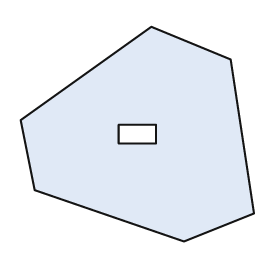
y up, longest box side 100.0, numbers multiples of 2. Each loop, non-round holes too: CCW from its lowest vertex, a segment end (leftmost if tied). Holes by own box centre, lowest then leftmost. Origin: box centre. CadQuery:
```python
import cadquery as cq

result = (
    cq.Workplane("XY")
    .moveTo(20.0, -46.0)
    .lineTo(50.0, -34.0)
    .lineTo(40.0, 32.0)
    .lineTo(6.0, 46.0)
    .lineTo(-50.0, 6.0)
    .lineTo(-44.0, -24.0)
    .close()
    .moveTo(-8.0, -4.0)
    .lineTo(8.0, -4.0)
    .lineTo(8.0, 4.0)
    .lineTo(-8.0, 4.0)
    .close()
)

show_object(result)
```